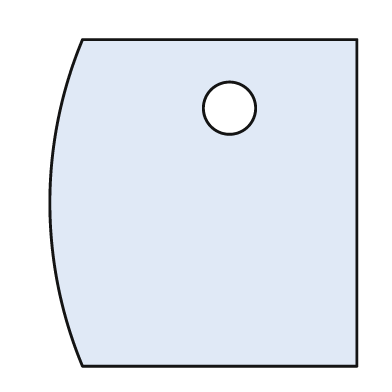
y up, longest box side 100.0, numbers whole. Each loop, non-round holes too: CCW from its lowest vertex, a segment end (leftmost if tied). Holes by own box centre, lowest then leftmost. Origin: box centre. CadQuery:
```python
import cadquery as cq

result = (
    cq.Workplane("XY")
    .moveTo(-37.0, -50.0)
    .lineTo(47.0, -50.0)
    .lineTo(47.0, 50.0)
    .lineTo(-37.0, 50.0)
    .threePointArc((-47.0, 0.0), (-37.0, -50.0))
    .close()
    .moveTo(8.0, 29.0)
    .circle(8.0)
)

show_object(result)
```